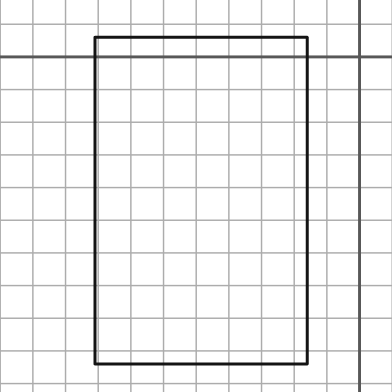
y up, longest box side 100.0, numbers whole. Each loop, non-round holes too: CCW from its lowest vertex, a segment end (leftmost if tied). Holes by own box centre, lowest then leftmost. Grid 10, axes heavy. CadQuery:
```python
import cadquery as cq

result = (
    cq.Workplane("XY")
    .moveTo(-81.0, -94.0)
    .lineTo(-16.0, -94.0)
    .lineTo(-16.0, 6.0)
    .lineTo(-81.0, 6.0)
    .close()
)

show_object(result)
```